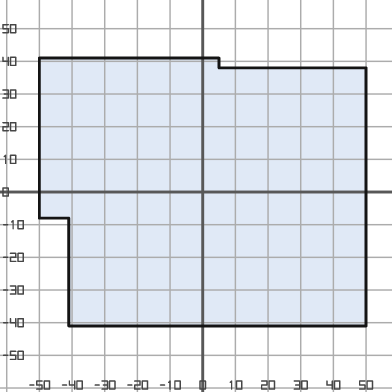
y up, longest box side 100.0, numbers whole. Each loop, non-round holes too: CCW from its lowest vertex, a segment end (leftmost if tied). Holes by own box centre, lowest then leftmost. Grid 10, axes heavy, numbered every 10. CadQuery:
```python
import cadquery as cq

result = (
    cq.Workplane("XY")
    .moveTo(-41.0, -41.0)
    .lineTo(50.0, -41.0)
    .lineTo(50.0, 38.0)
    .lineTo(5.0, 38.0)
    .lineTo(5.0, 41.0)
    .lineTo(-50.0, 41.0)
    .lineTo(-50.0, -8.0)
    .lineTo(-41.0, -8.0)
    .close()
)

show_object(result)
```